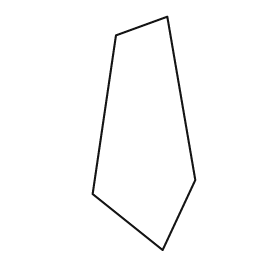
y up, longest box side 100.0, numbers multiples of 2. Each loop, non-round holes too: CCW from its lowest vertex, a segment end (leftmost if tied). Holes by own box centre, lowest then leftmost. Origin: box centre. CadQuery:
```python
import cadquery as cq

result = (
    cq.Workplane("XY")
    .moveTo(8.0, -50.0)
    .lineTo(22.0, -20.0)
    .lineTo(10.0, 50.0)
    .lineTo(-12.0, 42.0)
    .lineTo(-22.0, -26.0)
    .close()
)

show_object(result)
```